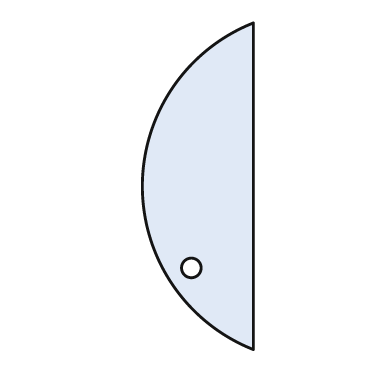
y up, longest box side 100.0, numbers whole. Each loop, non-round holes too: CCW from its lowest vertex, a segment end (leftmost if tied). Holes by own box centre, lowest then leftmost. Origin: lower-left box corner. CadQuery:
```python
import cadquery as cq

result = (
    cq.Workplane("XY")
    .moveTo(34.0, 0.0)
    .lineTo(34.0, 100.0)
    .threePointArc((0.0, 50.0), (34.0, 0.0))
    .close()
    .moveTo(15.0, 25.0)
    .circle(3.0)
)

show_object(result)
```